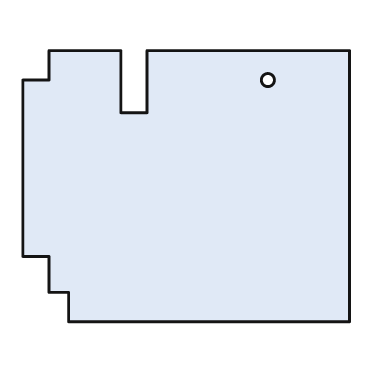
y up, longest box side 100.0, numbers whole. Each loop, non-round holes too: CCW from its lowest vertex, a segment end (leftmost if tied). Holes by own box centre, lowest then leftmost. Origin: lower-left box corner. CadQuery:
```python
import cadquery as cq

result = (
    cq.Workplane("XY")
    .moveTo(14.0, 0.0)
    .lineTo(100.0, 0.0)
    .lineTo(100.0, 83.0)
    .lineTo(38.0, 83.0)
    .lineTo(38.0, 64.0)
    .lineTo(30.0, 64.0)
    .lineTo(30.0, 83.0)
    .lineTo(8.0, 83.0)
    .lineTo(8.0, 74.0)
    .lineTo(0.0, 74.0)
    .lineTo(0.0, 20.0)
    .lineTo(8.0, 20.0)
    .lineTo(8.0, 9.0)
    .lineTo(14.0, 9.0)
    .close()
    .moveTo(75.0, 74.0)
    .circle(2.0)
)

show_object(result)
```